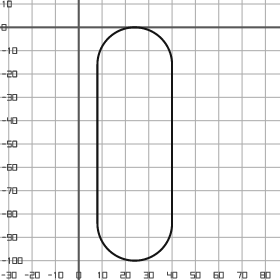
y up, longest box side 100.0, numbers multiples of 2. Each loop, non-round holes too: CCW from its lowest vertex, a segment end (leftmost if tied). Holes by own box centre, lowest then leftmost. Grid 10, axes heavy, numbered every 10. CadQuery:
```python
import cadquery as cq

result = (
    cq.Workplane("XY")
    .moveTo(8.0, -84.0)
    .threePointArc((24.0, -100.0), (40.0, -84.0))
    .lineTo(40.0, -16.0)
    .threePointArc((24.0, 0.0), (8.0, -16.0))
    .close()
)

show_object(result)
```